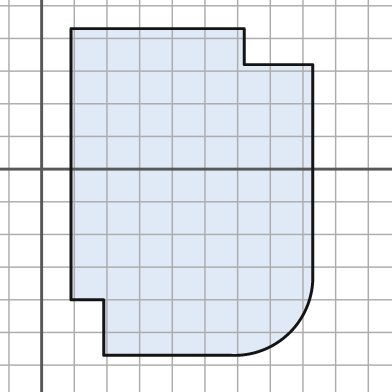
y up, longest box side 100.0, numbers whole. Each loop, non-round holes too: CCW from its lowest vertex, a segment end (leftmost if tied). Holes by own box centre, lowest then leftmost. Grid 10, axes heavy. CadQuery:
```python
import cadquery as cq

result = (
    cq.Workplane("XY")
    .moveTo(19.0, -57.0)
    .lineTo(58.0, -57.0)
    .threePointArc((76.0, -50.0), (83.0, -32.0))
    .lineTo(83.0, 32.0)
    .lineTo(62.0, 32.0)
    .lineTo(62.0, 43.0)
    .lineTo(9.0, 43.0)
    .lineTo(9.0, -40.0)
    .lineTo(19.0, -40.0)
    .close()
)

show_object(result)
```